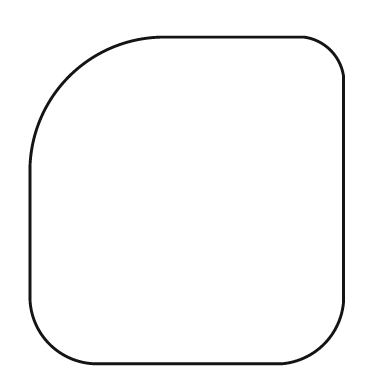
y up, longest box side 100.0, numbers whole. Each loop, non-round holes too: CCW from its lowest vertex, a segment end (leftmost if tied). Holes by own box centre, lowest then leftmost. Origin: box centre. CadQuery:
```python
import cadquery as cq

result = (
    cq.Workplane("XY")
    .moveTo(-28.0, -50.0)
    .lineTo(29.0, -50.0)
    .threePointArc((42.0, -44.0), (48.0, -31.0))
    .lineTo(48.0, 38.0)
    .threePointArc((44.0, 46.0), (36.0, 50.0))
    .lineTo(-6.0, 50.0)
    .threePointArc((-36.0, 38.0), (-48.0, 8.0))
    .lineTo(-48.0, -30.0)
    .threePointArc((-42.0, -44.0), (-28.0, -50.0))
    .close()
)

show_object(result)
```